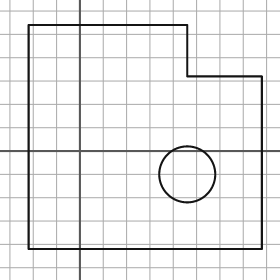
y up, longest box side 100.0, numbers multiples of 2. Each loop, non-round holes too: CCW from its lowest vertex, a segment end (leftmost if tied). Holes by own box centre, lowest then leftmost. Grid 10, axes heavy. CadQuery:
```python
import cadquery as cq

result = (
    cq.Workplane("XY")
    .moveTo(-22.0, -42.0)
    .lineTo(78.0, -42.0)
    .lineTo(78.0, 32.0)
    .lineTo(46.0, 32.0)
    .lineTo(46.0, 54.0)
    .lineTo(-22.0, 54.0)
    .close()
    .moveTo(46.0, -10.0)
    .circle(12.0)
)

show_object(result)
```